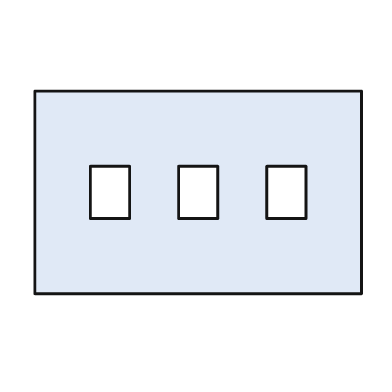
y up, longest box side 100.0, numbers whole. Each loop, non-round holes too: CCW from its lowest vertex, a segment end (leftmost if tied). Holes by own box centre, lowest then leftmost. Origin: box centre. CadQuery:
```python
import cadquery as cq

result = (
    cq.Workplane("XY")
    .moveTo(-50.0, -31.0)
    .lineTo(50.0, -31.0)
    .lineTo(50.0, 31.0)
    .lineTo(-50.0, 31.0)
    .close()
    .moveTo(-33.0, -8.0)
    .lineTo(-21.0, -8.0)
    .lineTo(-21.0, 8.0)
    .lineTo(-33.0, 8.0)
    .close()
    .moveTo(-6.0, -8.0)
    .lineTo(6.0, -8.0)
    .lineTo(6.0, 8.0)
    .lineTo(-6.0, 8.0)
    .close()
    .moveTo(21.0, -8.0)
    .lineTo(33.0, -8.0)
    .lineTo(33.0, 8.0)
    .lineTo(21.0, 8.0)
    .close()
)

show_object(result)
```